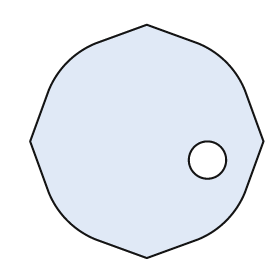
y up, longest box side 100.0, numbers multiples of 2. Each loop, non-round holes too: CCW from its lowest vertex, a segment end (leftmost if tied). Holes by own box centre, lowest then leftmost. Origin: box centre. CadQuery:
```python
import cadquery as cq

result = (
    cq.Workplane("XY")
    .moveTo(0.0, -50.0)
    .lineTo(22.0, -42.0)
    .threePointArc((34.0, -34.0), (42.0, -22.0))
    .lineTo(50.0, 0.0)
    .lineTo(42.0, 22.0)
    .threePointArc((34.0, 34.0), (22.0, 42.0))
    .lineTo(0.0, 50.0)
    .lineTo(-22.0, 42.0)
    .threePointArc((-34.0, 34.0), (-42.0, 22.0))
    .lineTo(-50.0, 0.0)
    .lineTo(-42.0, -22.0)
    .threePointArc((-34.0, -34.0), (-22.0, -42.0))
    .close()
    .moveTo(26.0, -8.0)
    .circle(8.0)
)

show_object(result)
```